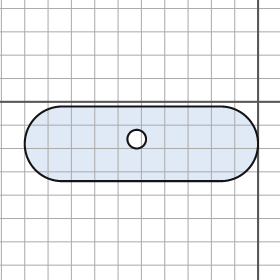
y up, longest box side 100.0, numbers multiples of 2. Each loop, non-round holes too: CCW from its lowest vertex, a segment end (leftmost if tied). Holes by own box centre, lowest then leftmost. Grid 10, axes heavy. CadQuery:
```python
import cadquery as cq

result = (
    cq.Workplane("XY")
    .moveTo(-84.0, -34.0)
    .lineTo(-16.0, -34.0)
    .threePointArc((0.0, -18.0), (-16.0, -2.0))
    .lineTo(-84.0, -2.0)
    .threePointArc((-100.0, -18.0), (-84.0, -34.0))
    .close()
    .moveTo(-52.0, -16.0)
    .circle(4.0)
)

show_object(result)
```